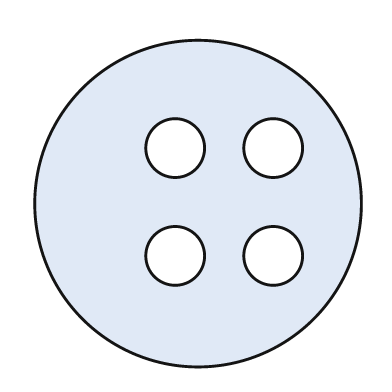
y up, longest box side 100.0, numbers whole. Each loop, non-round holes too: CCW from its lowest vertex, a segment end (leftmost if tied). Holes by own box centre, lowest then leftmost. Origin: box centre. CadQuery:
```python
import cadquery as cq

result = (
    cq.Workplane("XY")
    .moveTo(0.0, 0.0)
    .circle(50.0)
    .moveTo(-7.0, -16.0)
    .circle(9.0)
    .moveTo(23.0, -16.0)
    .circle(9.0)
    .moveTo(-7.0, 17.0)
    .circle(9.0)
    .moveTo(23.0, 17.0)
    .circle(9.0)
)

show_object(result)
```